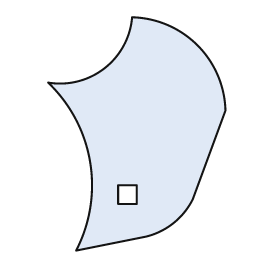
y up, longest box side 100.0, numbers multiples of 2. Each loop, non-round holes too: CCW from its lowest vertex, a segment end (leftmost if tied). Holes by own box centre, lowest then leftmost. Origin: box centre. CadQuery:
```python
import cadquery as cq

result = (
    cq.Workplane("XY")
    .moveTo(-26.0, -50.0)
    .lineTo(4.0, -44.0)
    .threePointArc((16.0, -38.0), (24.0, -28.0))
    .lineTo(38.0, 10.0)
    .threePointArc((26.0, 38.0), (-2.0, 50.0))
    .threePointArc((-14.0, 28.0), (-38.0, 22.0))
    .threePointArc((-20.0, -12.0), (-26.0, -50.0))
    .close()
    .moveTo(-8.0, -30.0)
    .lineTo(0.0, -30.0)
    .lineTo(0.0, -22.0)
    .lineTo(-8.0, -22.0)
    .close()
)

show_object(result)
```